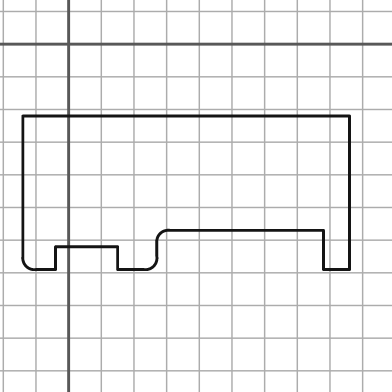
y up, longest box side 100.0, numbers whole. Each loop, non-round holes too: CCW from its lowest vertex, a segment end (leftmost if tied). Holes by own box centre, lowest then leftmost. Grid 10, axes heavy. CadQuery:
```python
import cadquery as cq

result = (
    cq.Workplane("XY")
    .moveTo(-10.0, -69.0)
    .lineTo(-4.0, -69.0)
    .lineTo(-4.0, -62.0)
    .lineTo(15.0, -62.0)
    .lineTo(15.0, -69.0)
    .lineTo(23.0, -69.0)
    .threePointArc((26.0, -68.0), (27.0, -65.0))
    .lineTo(27.0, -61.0)
    .threePointArc((28.0, -58.0), (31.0, -57.0))
    .lineTo(78.0, -57.0)
    .lineTo(78.0, -69.0)
    .lineTo(86.0, -69.0)
    .lineTo(86.0, -22.0)
    .lineTo(-14.0, -22.0)
    .lineTo(-14.0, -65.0)
    .threePointArc((-13.0, -68.0), (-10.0, -69.0))
    .close()
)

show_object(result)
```